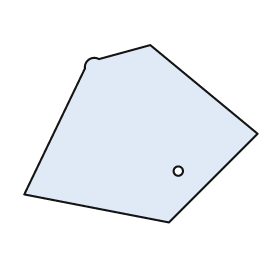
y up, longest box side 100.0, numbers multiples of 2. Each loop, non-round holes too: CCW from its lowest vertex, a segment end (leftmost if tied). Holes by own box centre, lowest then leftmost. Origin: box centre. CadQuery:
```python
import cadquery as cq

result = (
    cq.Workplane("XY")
    .moveTo(12.0, -38.0)
    .lineTo(50.0, 0.0)
    .lineTo(4.0, 38.0)
    .lineTo(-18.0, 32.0)
    .threePointArc((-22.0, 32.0), (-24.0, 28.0))
    .lineTo(-50.0, -26.0)
    .close()
    .moveTo(16.0, -16.0)
    .circle(2.0)
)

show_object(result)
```